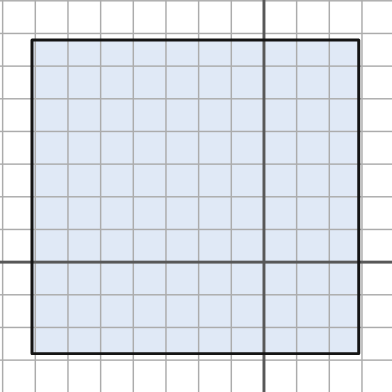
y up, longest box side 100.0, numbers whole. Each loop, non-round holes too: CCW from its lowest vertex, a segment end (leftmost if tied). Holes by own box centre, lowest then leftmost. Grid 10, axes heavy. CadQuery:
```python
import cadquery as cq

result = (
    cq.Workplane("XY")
    .moveTo(-71.0, -28.0)
    .lineTo(29.0, -28.0)
    .lineTo(29.0, 68.0)
    .lineTo(-71.0, 68.0)
    .close()
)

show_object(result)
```